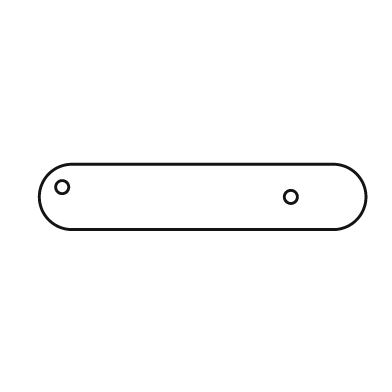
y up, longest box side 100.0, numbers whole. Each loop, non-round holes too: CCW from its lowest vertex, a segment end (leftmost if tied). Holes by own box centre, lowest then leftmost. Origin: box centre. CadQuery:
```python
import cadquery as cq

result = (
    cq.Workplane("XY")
    .moveTo(-40.0, -10.0)
    .lineTo(40.0, -10.0)
    .threePointArc((50.0, 0.0), (40.0, 10.0))
    .lineTo(-40.0, 10.0)
    .threePointArc((-50.0, 0.0), (-40.0, -10.0))
    .close()
    .moveTo(27.0, 0.0)
    .circle(2.0)
    .moveTo(-43.0, 3.0)
    .circle(2.0)
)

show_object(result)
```